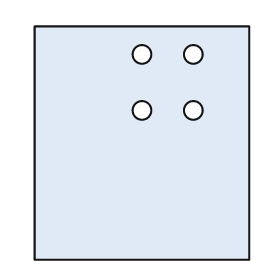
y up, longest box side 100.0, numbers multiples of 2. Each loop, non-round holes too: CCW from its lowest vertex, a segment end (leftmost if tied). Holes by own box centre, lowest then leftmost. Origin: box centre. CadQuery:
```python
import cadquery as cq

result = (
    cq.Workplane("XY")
    .moveTo(-46.0, -50.0)
    .lineTo(46.0, -50.0)
    .lineTo(46.0, 50.0)
    .lineTo(-46.0, 50.0)
    .close()
    .moveTo(0.0, 14.0)
    .circle(4.0)
    .moveTo(22.0, 14.0)
    .circle(4.0)
    .moveTo(0.0, 38.0)
    .circle(4.0)
    .moveTo(22.0, 38.0)
    .circle(4.0)
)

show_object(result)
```